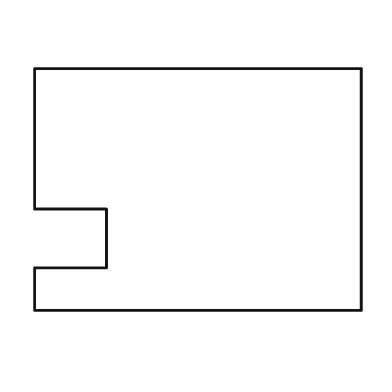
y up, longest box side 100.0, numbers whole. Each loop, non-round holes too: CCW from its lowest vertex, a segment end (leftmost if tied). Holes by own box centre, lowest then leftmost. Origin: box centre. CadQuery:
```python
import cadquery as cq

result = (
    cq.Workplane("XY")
    .moveTo(-50.0, -37.0)
    .lineTo(50.0, -37.0)
    .lineTo(50.0, 37.0)
    .lineTo(-50.0, 37.0)
    .lineTo(-50.0, -6.0)
    .lineTo(-28.0, -6.0)
    .lineTo(-28.0, -24.0)
    .lineTo(-50.0, -24.0)
    .close()
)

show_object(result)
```